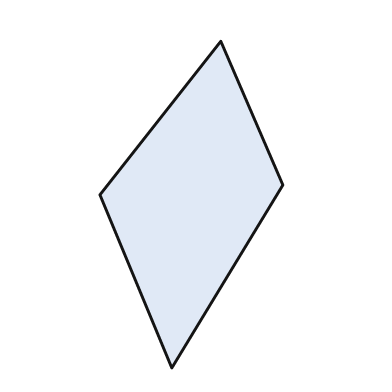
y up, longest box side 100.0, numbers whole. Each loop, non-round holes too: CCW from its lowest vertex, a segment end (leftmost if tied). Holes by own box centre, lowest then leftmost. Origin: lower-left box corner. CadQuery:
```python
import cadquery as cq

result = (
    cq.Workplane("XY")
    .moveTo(22.0, 0.0)
    .lineTo(56.0, 56.0)
    .lineTo(37.0, 100.0)
    .lineTo(0.0, 53.0)
    .close()
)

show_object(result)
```